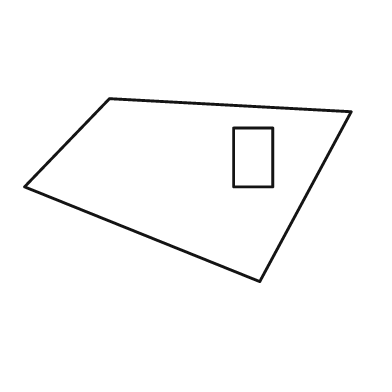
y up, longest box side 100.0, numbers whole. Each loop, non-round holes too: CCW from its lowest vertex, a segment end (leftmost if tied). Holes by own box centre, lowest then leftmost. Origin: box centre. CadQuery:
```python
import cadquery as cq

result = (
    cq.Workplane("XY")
    .moveTo(22.0, -28.0)
    .lineTo(50.0, 24.0)
    .lineTo(-24.0, 28.0)
    .lineTo(-50.0, 1.0)
    .close()
    .moveTo(14.0, 1.0)
    .lineTo(26.0, 1.0)
    .lineTo(26.0, 19.0)
    .lineTo(14.0, 19.0)
    .close()
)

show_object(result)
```